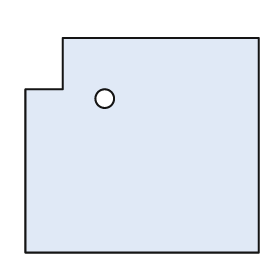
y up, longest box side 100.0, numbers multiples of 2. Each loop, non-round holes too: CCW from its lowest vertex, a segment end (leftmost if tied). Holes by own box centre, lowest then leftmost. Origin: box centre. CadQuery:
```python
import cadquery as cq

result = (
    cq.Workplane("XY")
    .moveTo(-50.0, -46.0)
    .lineTo(50.0, -46.0)
    .lineTo(50.0, 46.0)
    .lineTo(-34.0, 46.0)
    .lineTo(-34.0, 24.0)
    .lineTo(-50.0, 24.0)
    .close()
    .moveTo(-16.0, 20.0)
    .circle(4.0)
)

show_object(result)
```